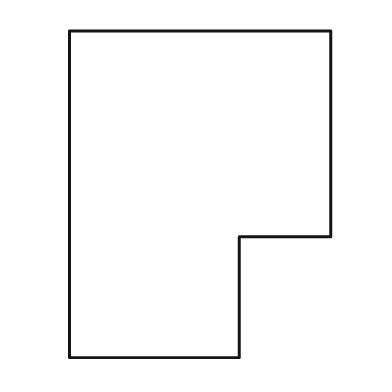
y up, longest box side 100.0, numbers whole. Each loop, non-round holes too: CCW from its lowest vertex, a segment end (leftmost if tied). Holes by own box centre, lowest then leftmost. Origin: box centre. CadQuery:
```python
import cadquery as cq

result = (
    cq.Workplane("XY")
    .moveTo(-40.0, -50.0)
    .lineTo(12.0, -50.0)
    .lineTo(12.0, -13.0)
    .lineTo(40.0, -13.0)
    .lineTo(40.0, 50.0)
    .lineTo(-40.0, 50.0)
    .close()
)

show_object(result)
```